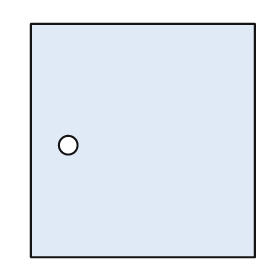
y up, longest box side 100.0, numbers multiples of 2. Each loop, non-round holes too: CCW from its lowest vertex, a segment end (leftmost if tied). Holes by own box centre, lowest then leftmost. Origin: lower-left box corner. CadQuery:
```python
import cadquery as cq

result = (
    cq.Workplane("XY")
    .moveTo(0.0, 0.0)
    .lineTo(96.0, 0.0)
    .lineTo(96.0, 100.0)
    .lineTo(0.0, 100.0)
    .close()
    .moveTo(16.0, 48.0)
    .circle(4.0)
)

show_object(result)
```